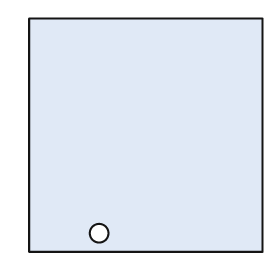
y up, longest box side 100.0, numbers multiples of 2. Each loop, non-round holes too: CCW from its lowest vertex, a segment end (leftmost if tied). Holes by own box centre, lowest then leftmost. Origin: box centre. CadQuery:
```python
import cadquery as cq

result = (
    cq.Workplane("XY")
    .moveTo(-50.0, -50.0)
    .lineTo(50.0, -50.0)
    .lineTo(50.0, 50.0)
    .lineTo(-50.0, 50.0)
    .close()
    .moveTo(-20.0, -42.0)
    .circle(4.0)
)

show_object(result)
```